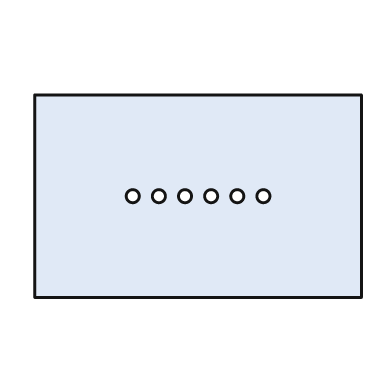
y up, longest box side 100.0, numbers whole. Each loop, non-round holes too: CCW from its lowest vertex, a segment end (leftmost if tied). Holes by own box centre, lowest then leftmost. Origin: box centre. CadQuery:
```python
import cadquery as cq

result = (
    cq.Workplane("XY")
    .moveTo(-50.0, -31.0)
    .lineTo(50.0, -31.0)
    .lineTo(50.0, 31.0)
    .lineTo(-50.0, 31.0)
    .close()
    .moveTo(-20.0, 0.0)
    .circle(2.0)
    .moveTo(-12.0, 0.0)
    .circle(2.0)
    .moveTo(-4.0, 0.0)
    .circle(2.0)
    .moveTo(4.0, 0.0)
    .circle(2.0)
    .moveTo(12.0, 0.0)
    .circle(2.0)
    .moveTo(20.0, 0.0)
    .circle(2.0)
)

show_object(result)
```